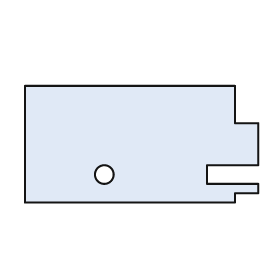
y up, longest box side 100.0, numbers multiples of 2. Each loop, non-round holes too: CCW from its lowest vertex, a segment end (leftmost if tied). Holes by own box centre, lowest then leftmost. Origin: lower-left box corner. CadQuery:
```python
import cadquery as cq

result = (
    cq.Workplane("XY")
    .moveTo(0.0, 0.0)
    .lineTo(90.0, 0.0)
    .lineTo(90.0, 4.0)
    .lineTo(100.0, 4.0)
    .lineTo(100.0, 8.0)
    .lineTo(78.0, 8.0)
    .lineTo(78.0, 16.0)
    .lineTo(100.0, 16.0)
    .lineTo(100.0, 34.0)
    .lineTo(90.0, 34.0)
    .lineTo(90.0, 50.0)
    .lineTo(0.0, 50.0)
    .close()
    .moveTo(34.0, 12.0)
    .circle(4.0)
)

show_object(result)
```